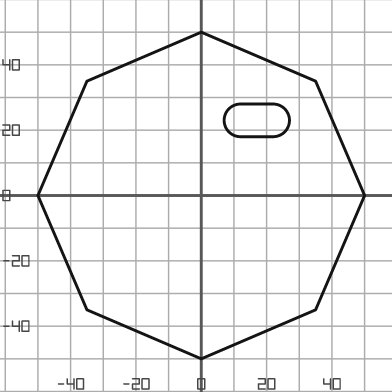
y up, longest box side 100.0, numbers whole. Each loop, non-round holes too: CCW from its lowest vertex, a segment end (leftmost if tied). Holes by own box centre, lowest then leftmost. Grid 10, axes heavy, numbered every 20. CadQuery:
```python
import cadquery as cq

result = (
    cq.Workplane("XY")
    .moveTo(0.0, -50.0)
    .lineTo(35.0, -35.0)
    .lineTo(50.0, 0.0)
    .lineTo(35.0, 35.0)
    .lineTo(0.0, 50.0)
    .lineTo(-35.0, 35.0)
    .lineTo(-50.0, 0.0)
    .lineTo(-35.0, -35.0)
    .close()
    .moveTo(12.0, 18.0)
    .lineTo(22.0, 18.0)
    .threePointArc((27.0, 23.0), (22.0, 28.0))
    .lineTo(12.0, 28.0)
    .threePointArc((7.0, 23.0), (12.0, 18.0))
    .close()
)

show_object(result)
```